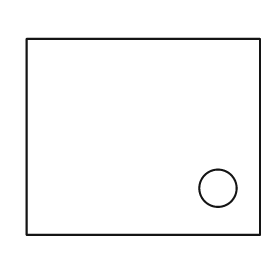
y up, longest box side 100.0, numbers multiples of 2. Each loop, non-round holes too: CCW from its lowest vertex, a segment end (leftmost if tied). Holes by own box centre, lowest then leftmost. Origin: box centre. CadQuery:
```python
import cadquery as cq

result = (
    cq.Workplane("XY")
    .moveTo(-50.0, -42.0)
    .lineTo(50.0, -42.0)
    .lineTo(50.0, 42.0)
    .lineTo(-50.0, 42.0)
    .close()
    .moveTo(32.0, -22.0)
    .circle(8.0)
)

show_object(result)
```